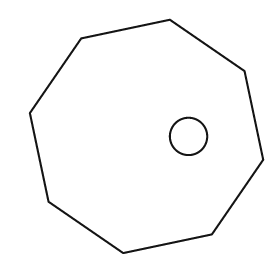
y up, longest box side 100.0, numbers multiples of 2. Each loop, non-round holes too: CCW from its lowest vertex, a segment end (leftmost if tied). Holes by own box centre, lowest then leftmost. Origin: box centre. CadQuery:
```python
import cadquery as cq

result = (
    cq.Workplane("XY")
    .moveTo(-10.0, -50.0)
    .lineTo(28.0, -42.0)
    .lineTo(50.0, -10.0)
    .lineTo(42.0, 28.0)
    .lineTo(10.0, 50.0)
    .lineTo(-28.0, 42.0)
    .lineTo(-50.0, 10.0)
    .lineTo(-42.0, -28.0)
    .close()
    .moveTo(18.0, 0.0)
    .circle(8.0)
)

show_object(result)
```